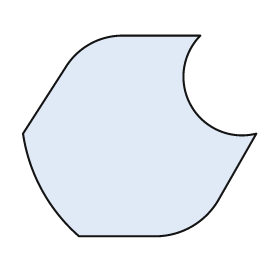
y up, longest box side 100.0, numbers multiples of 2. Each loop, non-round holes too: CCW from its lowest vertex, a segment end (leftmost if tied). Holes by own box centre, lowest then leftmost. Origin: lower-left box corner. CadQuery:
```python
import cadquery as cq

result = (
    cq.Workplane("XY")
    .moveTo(24.0, 0.0)
    .lineTo(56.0, 0.0)
    .threePointArc((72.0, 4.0), (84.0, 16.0))
    .lineTo(100.0, 44.0)
    .threePointArc((72.0, 56.0), (76.0, 86.0))
    .lineTo(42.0, 86.0)
    .threePointArc((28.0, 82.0), (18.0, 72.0))
    .lineTo(0.0, 44.0)
    .threePointArc((8.0, 20.0), (24.0, 0.0))
    .close()
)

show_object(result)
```